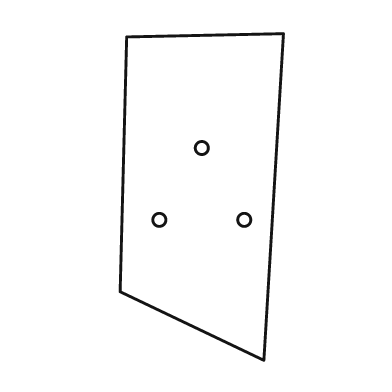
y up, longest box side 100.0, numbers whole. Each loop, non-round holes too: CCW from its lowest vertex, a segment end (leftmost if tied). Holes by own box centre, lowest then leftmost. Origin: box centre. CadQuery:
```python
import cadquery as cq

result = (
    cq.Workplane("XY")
    .moveTo(19.0, -50.0)
    .lineTo(25.0, 50.0)
    .lineTo(-23.0, 49.0)
    .lineTo(-25.0, -29.0)
    .close()
    .moveTo(-13.0, -7.0)
    .circle(2.0)
    .moveTo(13.0, -7.0)
    .circle(2.0)
    .moveTo(0.0, 15.0)
    .circle(2.0)
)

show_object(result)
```